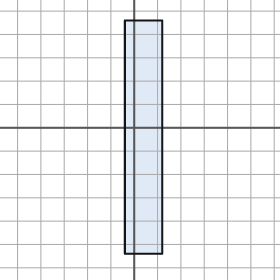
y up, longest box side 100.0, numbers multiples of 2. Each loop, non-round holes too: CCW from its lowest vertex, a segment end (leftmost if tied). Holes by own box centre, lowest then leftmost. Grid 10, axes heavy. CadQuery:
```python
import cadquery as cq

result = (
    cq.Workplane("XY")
    .moveTo(-4.0, -54.0)
    .lineTo(12.0, -54.0)
    .lineTo(12.0, 46.0)
    .lineTo(-4.0, 46.0)
    .close()
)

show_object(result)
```